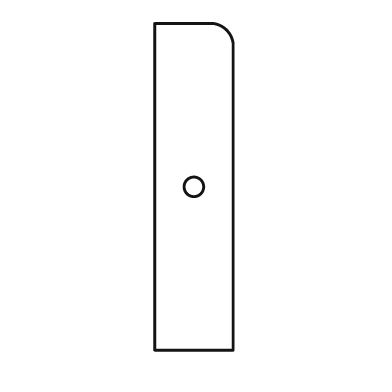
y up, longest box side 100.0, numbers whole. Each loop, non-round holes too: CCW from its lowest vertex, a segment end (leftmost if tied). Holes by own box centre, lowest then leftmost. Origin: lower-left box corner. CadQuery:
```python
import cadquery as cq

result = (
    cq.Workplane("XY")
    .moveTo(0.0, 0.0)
    .lineTo(24.0, 0.0)
    .lineTo(24.0, 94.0)
    .threePointArc((22.0, 98.0), (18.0, 100.0))
    .lineTo(0.0, 100.0)
    .close()
    .moveTo(12.0, 50.0)
    .circle(3.0)
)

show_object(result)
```